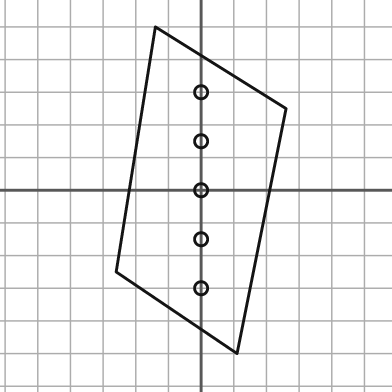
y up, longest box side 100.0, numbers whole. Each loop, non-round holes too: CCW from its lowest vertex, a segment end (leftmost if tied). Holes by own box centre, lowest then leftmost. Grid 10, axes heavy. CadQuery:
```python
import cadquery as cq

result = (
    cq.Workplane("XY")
    .moveTo(11.0, -50.0)
    .lineTo(26.0, 25.0)
    .lineTo(-14.0, 50.0)
    .lineTo(-26.0, -25.0)
    .close()
    .moveTo(0.0, -30.0)
    .circle(2.0)
    .moveTo(0.0, -15.0)
    .circle(2.0)
    .moveTo(0.0, 0.0)
    .circle(2.0)
    .moveTo(0.0, 15.0)
    .circle(2.0)
    .moveTo(0.0, 30.0)
    .circle(2.0)
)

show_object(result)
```